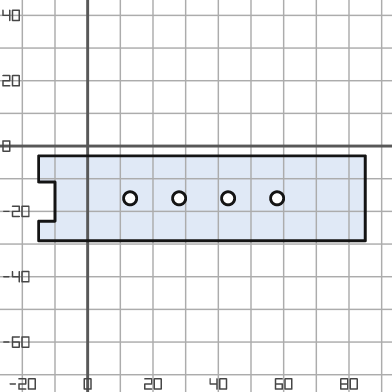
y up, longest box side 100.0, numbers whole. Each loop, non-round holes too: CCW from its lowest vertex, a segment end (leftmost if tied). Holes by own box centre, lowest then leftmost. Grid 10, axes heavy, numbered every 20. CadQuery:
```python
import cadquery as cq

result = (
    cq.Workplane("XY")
    .moveTo(-15.0, -29.0)
    .lineTo(85.0, -29.0)
    .lineTo(85.0, -3.0)
    .lineTo(-15.0, -3.0)
    .lineTo(-15.0, -11.0)
    .lineTo(-10.0, -11.0)
    .lineTo(-10.0, -23.0)
    .lineTo(-15.0, -23.0)
    .close()
    .moveTo(13.0, -16.0)
    .circle(2.0)
    .moveTo(28.0, -16.0)
    .circle(2.0)
    .moveTo(43.0, -16.0)
    .circle(2.0)
    .moveTo(58.0, -16.0)
    .circle(2.0)
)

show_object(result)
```